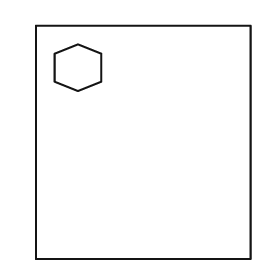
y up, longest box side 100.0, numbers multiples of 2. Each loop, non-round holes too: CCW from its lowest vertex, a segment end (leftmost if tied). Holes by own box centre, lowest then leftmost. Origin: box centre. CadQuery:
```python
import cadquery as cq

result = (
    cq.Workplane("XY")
    .moveTo(-46.0, -50.0)
    .lineTo(46.0, -50.0)
    .lineTo(46.0, 50.0)
    .lineTo(-46.0, 50.0)
    .close()
    .moveTo(-28.0, 22.0)
    .lineTo(-18.0, 26.0)
    .lineTo(-18.0, 38.0)
    .lineTo(-28.0, 42.0)
    .lineTo(-38.0, 38.0)
    .lineTo(-38.0, 26.0)
    .close()
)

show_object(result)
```